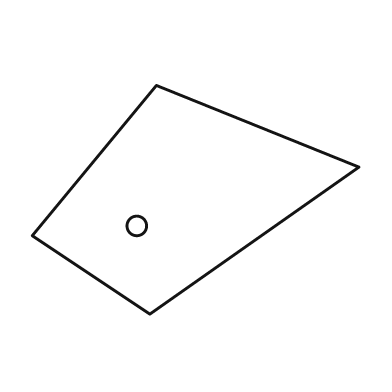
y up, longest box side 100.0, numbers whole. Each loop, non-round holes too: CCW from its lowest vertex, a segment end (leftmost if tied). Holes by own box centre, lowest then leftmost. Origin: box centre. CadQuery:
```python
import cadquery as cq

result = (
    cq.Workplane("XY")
    .moveTo(-14.0, -35.0)
    .lineTo(50.0, 10.0)
    .lineTo(-12.0, 35.0)
    .lineTo(-50.0, -11.0)
    .close()
    .moveTo(-18.0, -8.0)
    .circle(3.0)
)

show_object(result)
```